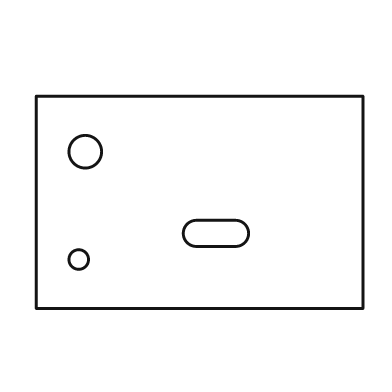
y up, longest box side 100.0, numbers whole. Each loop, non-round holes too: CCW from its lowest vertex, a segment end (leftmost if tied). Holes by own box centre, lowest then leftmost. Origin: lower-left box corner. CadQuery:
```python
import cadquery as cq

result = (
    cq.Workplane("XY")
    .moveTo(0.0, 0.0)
    .lineTo(100.0, 0.0)
    .lineTo(100.0, 65.0)
    .lineTo(0.0, 65.0)
    .close()
    .moveTo(13.0, 15.0)
    .circle(3.0)
    .moveTo(49.0, 19.0)
    .lineTo(61.0, 19.0)
    .threePointArc((65.0, 23.0), (61.0, 27.0))
    .lineTo(49.0, 27.0)
    .threePointArc((45.0, 23.0), (49.0, 19.0))
    .close()
    .moveTo(15.0, 48.0)
    .circle(5.0)
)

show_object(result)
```